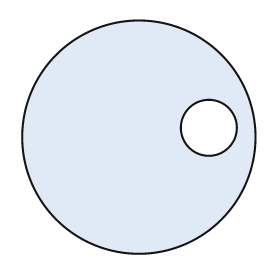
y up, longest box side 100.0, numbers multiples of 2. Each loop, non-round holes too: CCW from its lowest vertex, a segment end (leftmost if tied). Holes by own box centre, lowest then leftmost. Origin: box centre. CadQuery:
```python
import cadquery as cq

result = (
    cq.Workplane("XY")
    .moveTo(0.0, 0.0)
    .circle(50.0)
    .moveTo(30.0, 4.0)
    .circle(12.0)
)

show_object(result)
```